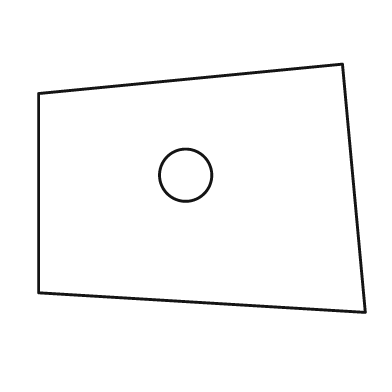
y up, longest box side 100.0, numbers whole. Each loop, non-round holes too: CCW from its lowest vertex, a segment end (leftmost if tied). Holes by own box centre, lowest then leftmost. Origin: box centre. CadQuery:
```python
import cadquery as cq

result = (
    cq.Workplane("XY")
    .moveTo(50.0, -38.0)
    .lineTo(43.0, 38.0)
    .lineTo(-50.0, 29.0)
    .lineTo(-50.0, -32.0)
    .close()
    .moveTo(-5.0, 4.0)
    .circle(8.0)
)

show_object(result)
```